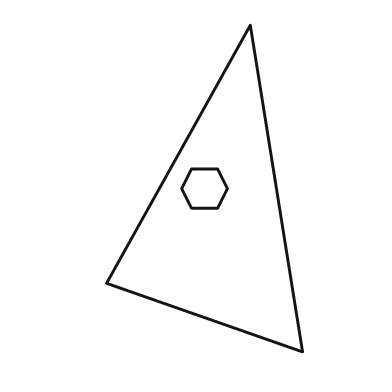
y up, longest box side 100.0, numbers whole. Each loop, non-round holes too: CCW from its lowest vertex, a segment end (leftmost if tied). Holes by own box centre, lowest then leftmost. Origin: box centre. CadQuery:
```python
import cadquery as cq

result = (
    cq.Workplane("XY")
    .moveTo(30.0, -50.0)
    .lineTo(14.0, 50.0)
    .lineTo(-30.0, -29.0)
    .close()
    .moveTo(-4.0, -6.0)
    .lineTo(4.0, -6.0)
    .lineTo(7.0, 0.0)
    .lineTo(4.0, 6.0)
    .lineTo(-4.0, 6.0)
    .lineTo(-7.0, 0.0)
    .close()
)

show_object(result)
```